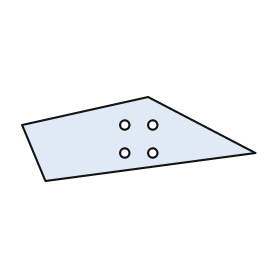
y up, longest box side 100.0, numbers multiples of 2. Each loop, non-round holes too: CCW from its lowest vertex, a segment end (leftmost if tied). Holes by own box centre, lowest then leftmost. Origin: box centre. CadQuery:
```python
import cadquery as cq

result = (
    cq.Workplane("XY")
    .moveTo(-40.0, -18.0)
    .lineTo(50.0, -6.0)
    .lineTo(4.0, 18.0)
    .lineTo(-50.0, 6.0)
    .close()
    .moveTo(-6.0, -6.0)
    .circle(2.0)
    .moveTo(6.0, -6.0)
    .circle(2.0)
    .moveTo(-6.0, 6.0)
    .circle(2.0)
    .moveTo(6.0, 6.0)
    .circle(2.0)
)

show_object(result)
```